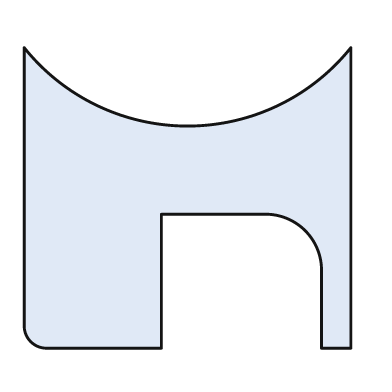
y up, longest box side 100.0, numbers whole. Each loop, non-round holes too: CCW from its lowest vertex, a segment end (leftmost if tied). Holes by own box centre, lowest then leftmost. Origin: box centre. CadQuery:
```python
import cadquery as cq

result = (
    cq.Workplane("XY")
    .moveTo(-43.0, -46.0)
    .lineTo(-8.0, -46.0)
    .lineTo(-8.0, -5.0)
    .lineTo(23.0, -5.0)
    .threePointArc((36.0, -10.0), (41.0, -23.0))
    .lineTo(41.0, -46.0)
    .lineTo(50.0, -46.0)
    .lineTo(50.0, 46.0)
    .threePointArc((0.0, 22.0), (-50.0, 46.0))
    .lineTo(-50.0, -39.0)
    .threePointArc((-48.0, -44.0), (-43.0, -46.0))
    .close()
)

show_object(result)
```